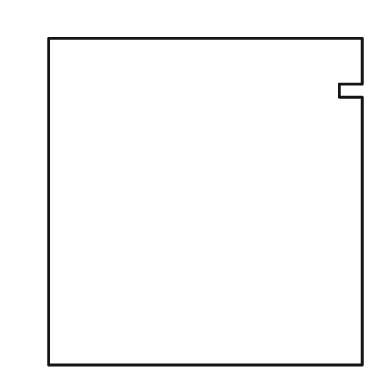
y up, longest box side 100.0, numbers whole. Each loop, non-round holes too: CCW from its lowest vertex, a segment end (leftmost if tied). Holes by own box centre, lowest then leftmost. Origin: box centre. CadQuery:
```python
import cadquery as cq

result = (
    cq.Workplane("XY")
    .moveTo(-48.0, -50.0)
    .lineTo(48.0, -50.0)
    .lineTo(48.0, 32.0)
    .lineTo(41.0, 32.0)
    .lineTo(41.0, 36.0)
    .lineTo(48.0, 36.0)
    .lineTo(48.0, 50.0)
    .lineTo(-48.0, 50.0)
    .close()
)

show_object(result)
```